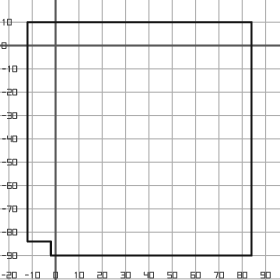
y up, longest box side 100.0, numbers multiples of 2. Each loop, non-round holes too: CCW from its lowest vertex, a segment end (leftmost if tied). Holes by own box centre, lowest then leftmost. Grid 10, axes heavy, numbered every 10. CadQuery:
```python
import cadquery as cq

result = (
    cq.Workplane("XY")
    .moveTo(-2.0, -90.0)
    .lineTo(84.0, -90.0)
    .lineTo(84.0, 10.0)
    .lineTo(-12.0, 10.0)
    .lineTo(-12.0, -84.0)
    .lineTo(-2.0, -84.0)
    .close()
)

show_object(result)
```